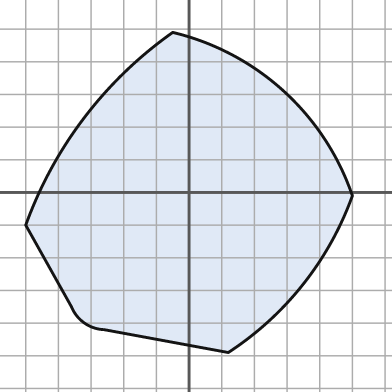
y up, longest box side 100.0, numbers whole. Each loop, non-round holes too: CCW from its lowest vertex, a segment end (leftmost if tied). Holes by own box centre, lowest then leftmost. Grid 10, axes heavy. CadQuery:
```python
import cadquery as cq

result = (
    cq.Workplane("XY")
    .moveTo(12.0, -49.0)
    .threePointArc((35.0, -28.0), (50.0, -1.0))
    .threePointArc((29.0, 31.0), (-5.0, 49.0))
    .threePointArc((-32.0, 23.0), (-50.0, -10.0))
    .lineTo(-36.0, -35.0)
    .threePointArc((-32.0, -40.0), (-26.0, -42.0))
    .close()
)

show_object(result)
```